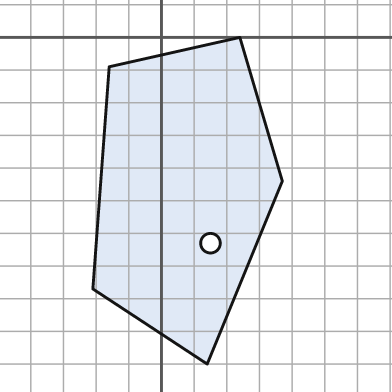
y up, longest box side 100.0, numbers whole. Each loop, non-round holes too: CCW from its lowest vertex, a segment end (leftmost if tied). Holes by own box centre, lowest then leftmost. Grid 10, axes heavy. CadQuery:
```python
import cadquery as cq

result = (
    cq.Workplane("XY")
    .moveTo(14.0, -100.0)
    .lineTo(37.0, -44.0)
    .lineTo(24.0, 0.0)
    .lineTo(-16.0, -9.0)
    .lineTo(-21.0, -77.0)
    .close()
    .moveTo(15.0, -63.0)
    .circle(3.0)
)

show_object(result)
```